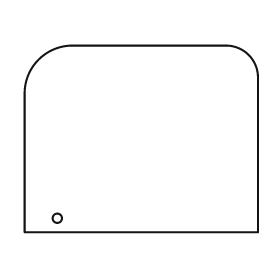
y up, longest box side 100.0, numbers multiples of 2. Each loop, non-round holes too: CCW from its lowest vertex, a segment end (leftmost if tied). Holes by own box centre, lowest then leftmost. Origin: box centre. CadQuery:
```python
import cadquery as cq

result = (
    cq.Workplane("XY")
    .moveTo(-50.0, -40.0)
    .lineTo(50.0, -40.0)
    .lineTo(50.0, 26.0)
    .threePointArc((46.0, 36.0), (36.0, 40.0))
    .lineTo(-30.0, 40.0)
    .threePointArc((-44.0, 34.0), (-50.0, 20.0))
    .close()
    .moveTo(-36.0, -34.0)
    .circle(2.0)
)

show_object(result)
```